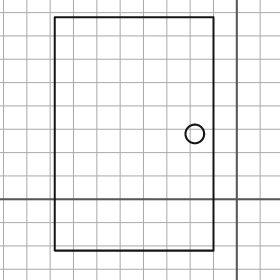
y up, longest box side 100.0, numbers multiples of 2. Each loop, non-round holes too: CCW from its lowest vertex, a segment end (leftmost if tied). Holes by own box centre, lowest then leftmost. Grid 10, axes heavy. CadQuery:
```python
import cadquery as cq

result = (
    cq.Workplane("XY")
    .moveTo(-78.0, -22.0)
    .lineTo(-10.0, -22.0)
    .lineTo(-10.0, 78.0)
    .lineTo(-78.0, 78.0)
    .close()
    .moveTo(-18.0, 28.0)
    .circle(4.0)
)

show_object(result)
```